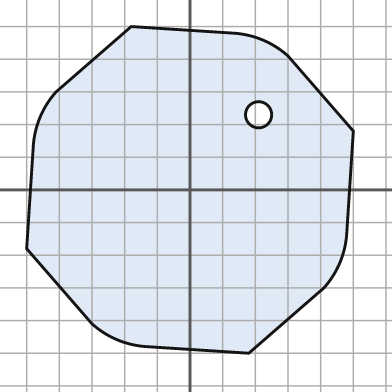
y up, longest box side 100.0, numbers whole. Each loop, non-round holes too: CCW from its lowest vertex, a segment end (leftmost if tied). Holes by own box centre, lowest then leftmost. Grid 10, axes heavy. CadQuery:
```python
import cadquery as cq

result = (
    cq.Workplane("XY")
    .moveTo(18.0, -50.0)
    .lineTo(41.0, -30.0)
    .threePointArc((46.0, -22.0), (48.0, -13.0))
    .lineTo(50.0, 18.0)
    .lineTo(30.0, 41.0)
    .threePointArc((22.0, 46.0), (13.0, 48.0))
    .lineTo(-18.0, 50.0)
    .lineTo(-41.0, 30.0)
    .threePointArc((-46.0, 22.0), (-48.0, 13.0))
    .lineTo(-50.0, -18.0)
    .lineTo(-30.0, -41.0)
    .threePointArc((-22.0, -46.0), (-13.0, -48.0))
    .close()
    .moveTo(21.0, 23.0)
    .circle(4.0)
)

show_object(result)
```